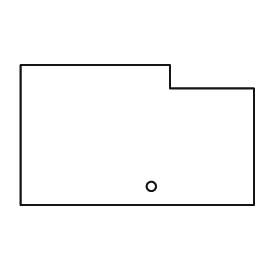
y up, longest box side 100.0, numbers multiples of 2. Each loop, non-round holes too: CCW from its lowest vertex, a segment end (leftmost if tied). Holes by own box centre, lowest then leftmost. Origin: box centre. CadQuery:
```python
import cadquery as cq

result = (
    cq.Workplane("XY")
    .moveTo(-50.0, -30.0)
    .lineTo(50.0, -30.0)
    .lineTo(50.0, 20.0)
    .lineTo(14.0, 20.0)
    .lineTo(14.0, 30.0)
    .lineTo(-50.0, 30.0)
    .close()
    .moveTo(6.0, -22.0)
    .circle(2.0)
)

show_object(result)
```